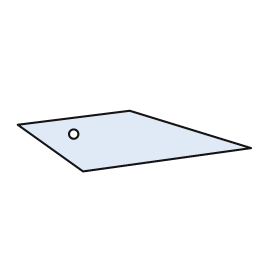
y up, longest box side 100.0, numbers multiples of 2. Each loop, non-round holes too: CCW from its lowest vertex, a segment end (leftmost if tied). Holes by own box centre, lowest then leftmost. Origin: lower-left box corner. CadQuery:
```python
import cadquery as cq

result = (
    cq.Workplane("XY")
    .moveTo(28.0, 0.0)
    .lineTo(100.0, 10.0)
    .lineTo(48.0, 26.0)
    .lineTo(0.0, 20.0)
    .close()
    .moveTo(24.0, 16.0)
    .circle(2.0)
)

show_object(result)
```